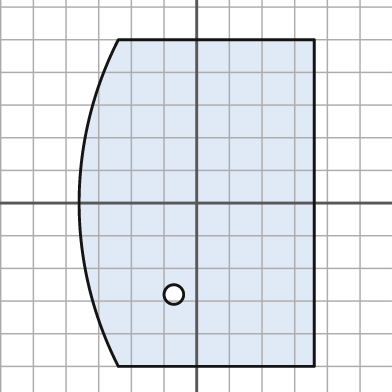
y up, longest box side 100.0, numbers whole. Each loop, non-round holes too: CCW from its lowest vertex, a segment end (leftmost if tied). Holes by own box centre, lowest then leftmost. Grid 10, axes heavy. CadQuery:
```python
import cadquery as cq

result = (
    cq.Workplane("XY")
    .moveTo(-24.0, -50.0)
    .lineTo(36.0, -50.0)
    .lineTo(36.0, 50.0)
    .lineTo(-24.0, 50.0)
    .threePointArc((-36.0, 0.0), (-24.0, -50.0))
    .close()
    .moveTo(-7.0, -28.0)
    .circle(3.0)
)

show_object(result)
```